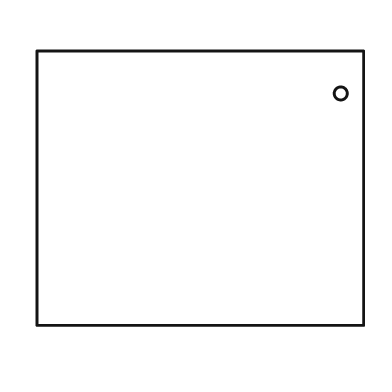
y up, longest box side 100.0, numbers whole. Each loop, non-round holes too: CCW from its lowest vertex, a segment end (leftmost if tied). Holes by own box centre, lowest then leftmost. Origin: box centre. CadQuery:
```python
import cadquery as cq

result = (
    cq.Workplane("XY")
    .moveTo(-50.0, -42.0)
    .lineTo(50.0, -42.0)
    .lineTo(50.0, 42.0)
    .lineTo(-50.0, 42.0)
    .close()
    .moveTo(43.0, 29.0)
    .circle(2.0)
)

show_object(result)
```